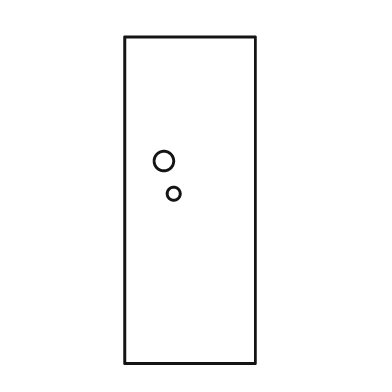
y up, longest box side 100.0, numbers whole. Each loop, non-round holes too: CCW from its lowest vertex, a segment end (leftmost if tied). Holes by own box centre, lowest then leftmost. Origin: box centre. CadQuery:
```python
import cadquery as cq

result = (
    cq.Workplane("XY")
    .moveTo(-20.0, -50.0)
    .lineTo(20.0, -50.0)
    .lineTo(20.0, 50.0)
    .lineTo(-20.0, 50.0)
    .close()
    .moveTo(-5.0, 2.0)
    .circle(2.0)
    .moveTo(-8.0, 12.0)
    .circle(3.0)
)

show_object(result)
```